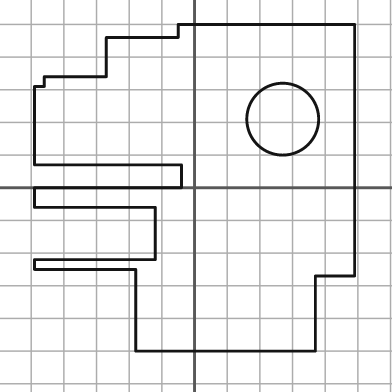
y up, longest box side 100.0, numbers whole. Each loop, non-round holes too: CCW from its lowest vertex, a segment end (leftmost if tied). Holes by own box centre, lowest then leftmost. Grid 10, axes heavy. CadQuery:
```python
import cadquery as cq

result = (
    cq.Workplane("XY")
    .moveTo(-18.0, -50.0)
    .lineTo(37.0, -50.0)
    .lineTo(37.0, -27.0)
    .lineTo(49.0, -27.0)
    .lineTo(49.0, 50.0)
    .lineTo(-5.0, 50.0)
    .lineTo(-5.0, 46.0)
    .lineTo(-27.0, 46.0)
    .lineTo(-27.0, 34.0)
    .lineTo(-46.0, 34.0)
    .lineTo(-46.0, 31.0)
    .lineTo(-49.0, 31.0)
    .lineTo(-49.0, 7.0)
    .lineTo(-4.0, 7.0)
    .lineTo(-4.0, 0.0)
    .lineTo(-49.0, 0.0)
    .lineTo(-49.0, -6.0)
    .lineTo(-12.0, -6.0)
    .lineTo(-12.0, -22.0)
    .lineTo(-49.0, -22.0)
    .lineTo(-49.0, -25.0)
    .lineTo(-18.0, -25.0)
    .close()
    .moveTo(27.0, 21.0)
    .circle(11.0)
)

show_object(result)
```